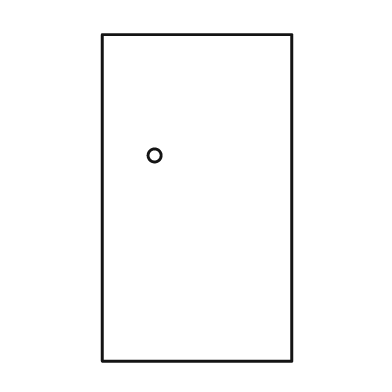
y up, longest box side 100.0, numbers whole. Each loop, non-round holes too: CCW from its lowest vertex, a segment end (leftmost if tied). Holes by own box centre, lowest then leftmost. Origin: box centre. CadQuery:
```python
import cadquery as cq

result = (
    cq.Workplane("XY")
    .moveTo(-29.0, -50.0)
    .lineTo(29.0, -50.0)
    .lineTo(29.0, 50.0)
    .lineTo(-29.0, 50.0)
    .close()
    .moveTo(-13.0, 13.0)
    .circle(2.0)
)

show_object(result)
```